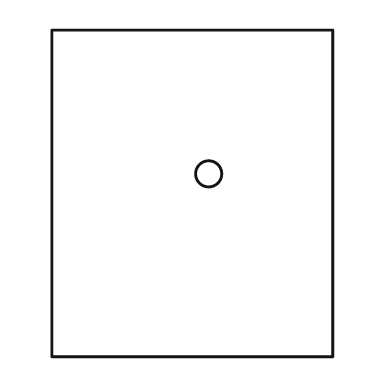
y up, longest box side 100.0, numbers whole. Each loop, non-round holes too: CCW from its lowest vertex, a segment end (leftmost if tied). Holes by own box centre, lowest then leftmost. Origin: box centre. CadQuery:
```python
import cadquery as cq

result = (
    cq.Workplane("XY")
    .moveTo(-43.0, -50.0)
    .lineTo(43.0, -50.0)
    .lineTo(43.0, 50.0)
    .lineTo(-43.0, 50.0)
    .close()
    .moveTo(5.0, 6.0)
    .circle(4.0)
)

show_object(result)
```